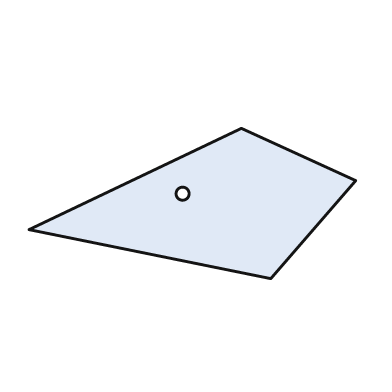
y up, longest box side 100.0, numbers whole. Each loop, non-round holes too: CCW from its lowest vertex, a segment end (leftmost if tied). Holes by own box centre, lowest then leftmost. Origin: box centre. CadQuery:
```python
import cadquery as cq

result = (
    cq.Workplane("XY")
    .moveTo(24.0, -23.0)
    .lineTo(50.0, 7.0)
    .lineTo(15.0, 23.0)
    .lineTo(-50.0, -8.0)
    .close()
    .moveTo(-3.0, 3.0)
    .circle(2.0)
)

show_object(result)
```